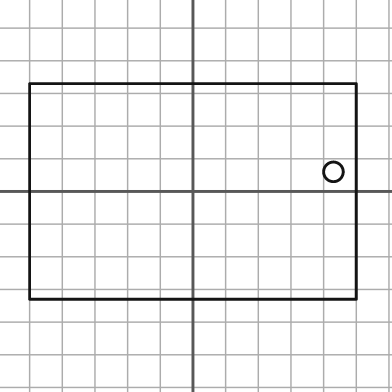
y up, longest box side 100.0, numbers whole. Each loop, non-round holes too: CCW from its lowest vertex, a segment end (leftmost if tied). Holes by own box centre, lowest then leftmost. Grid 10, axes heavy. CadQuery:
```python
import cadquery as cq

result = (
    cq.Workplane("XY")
    .moveTo(-50.0, -33.0)
    .lineTo(50.0, -33.0)
    .lineTo(50.0, 33.0)
    .lineTo(-50.0, 33.0)
    .close()
    .moveTo(43.0, 6.0)
    .circle(3.0)
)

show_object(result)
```